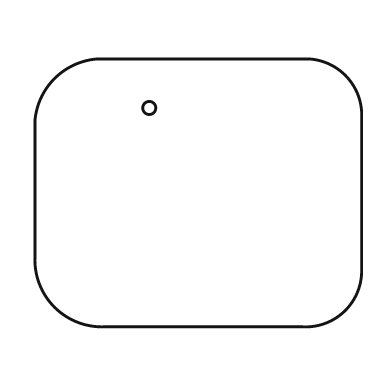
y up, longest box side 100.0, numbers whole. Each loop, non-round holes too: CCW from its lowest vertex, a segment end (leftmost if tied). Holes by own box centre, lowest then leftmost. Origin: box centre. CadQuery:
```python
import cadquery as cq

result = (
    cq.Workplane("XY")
    .moveTo(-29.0, -41.0)
    .lineTo(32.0, -41.0)
    .threePointArc((45.0, -36.0), (50.0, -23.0))
    .lineTo(50.0, 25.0)
    .threePointArc((45.0, 36.0), (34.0, 41.0))
    .lineTo(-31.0, 41.0)
    .threePointArc((-44.0, 35.0), (-50.0, 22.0))
    .lineTo(-50.0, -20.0)
    .threePointArc((-44.0, -35.0), (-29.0, -41.0))
    .close()
    .moveTo(-15.0, 26.0)
    .circle(2.0)
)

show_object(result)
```